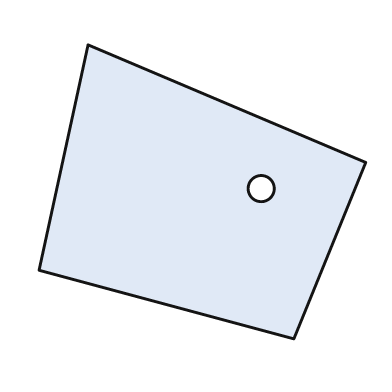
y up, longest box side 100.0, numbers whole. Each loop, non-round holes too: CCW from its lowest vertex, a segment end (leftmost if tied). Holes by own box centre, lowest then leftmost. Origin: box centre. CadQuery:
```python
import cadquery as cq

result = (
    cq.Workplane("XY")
    .moveTo(28.0, -45.0)
    .lineTo(50.0, 9.0)
    .lineTo(-35.0, 45.0)
    .lineTo(-50.0, -24.0)
    .close()
    .moveTo(18.0, 1.0)
    .circle(4.0)
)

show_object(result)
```